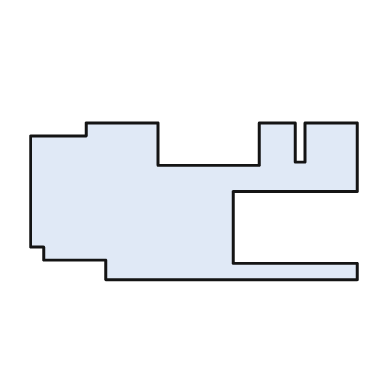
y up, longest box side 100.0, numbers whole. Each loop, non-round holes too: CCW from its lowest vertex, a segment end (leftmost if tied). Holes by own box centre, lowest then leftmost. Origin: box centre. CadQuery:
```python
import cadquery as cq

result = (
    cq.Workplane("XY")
    .moveTo(-27.0, -24.0)
    .lineTo(50.0, -24.0)
    .lineTo(50.0, -19.0)
    .lineTo(12.0, -19.0)
    .lineTo(12.0, 3.0)
    .lineTo(50.0, 3.0)
    .lineTo(50.0, 24.0)
    .lineTo(34.0, 24.0)
    .lineTo(34.0, 12.0)
    .lineTo(31.0, 12.0)
    .lineTo(31.0, 24.0)
    .lineTo(20.0, 24.0)
    .lineTo(20.0, 11.0)
    .lineTo(-11.0, 11.0)
    .lineTo(-11.0, 24.0)
    .lineTo(-33.0, 24.0)
    .lineTo(-33.0, 20.0)
    .lineTo(-50.0, 20.0)
    .lineTo(-50.0, -14.0)
    .lineTo(-46.0, -14.0)
    .lineTo(-46.0, -18.0)
    .lineTo(-27.0, -18.0)
    .close()
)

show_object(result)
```